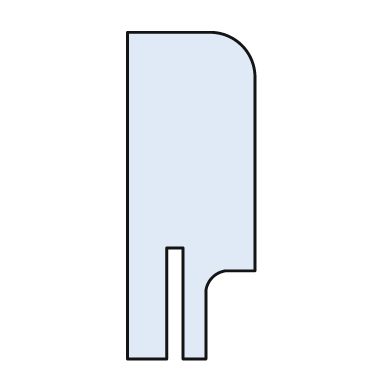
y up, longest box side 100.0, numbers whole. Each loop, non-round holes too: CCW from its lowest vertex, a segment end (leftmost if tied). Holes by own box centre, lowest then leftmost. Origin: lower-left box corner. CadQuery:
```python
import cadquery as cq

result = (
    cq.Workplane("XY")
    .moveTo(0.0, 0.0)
    .lineTo(12.0, 0.0)
    .lineTo(12.0, 34.0)
    .lineTo(17.0, 34.0)
    .lineTo(17.0, 0.0)
    .lineTo(24.0, 0.0)
    .lineTo(24.0, 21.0)
    .threePointArc((26.0, 25.0), (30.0, 27.0))
    .lineTo(39.0, 27.0)
    .lineTo(39.0, 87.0)
    .threePointArc((35.0, 96.0), (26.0, 100.0))
    .lineTo(0.0, 100.0)
    .close()
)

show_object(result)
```